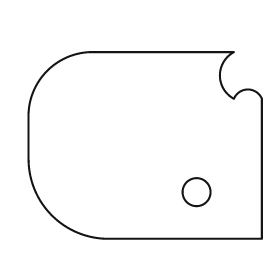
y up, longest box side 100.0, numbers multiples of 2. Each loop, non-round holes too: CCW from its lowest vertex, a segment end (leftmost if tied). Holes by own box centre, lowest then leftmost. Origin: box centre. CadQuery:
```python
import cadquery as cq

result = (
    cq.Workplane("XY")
    .moveTo(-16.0, -40.0)
    .lineTo(50.0, -40.0)
    .lineTo(50.0, 20.0)
    .threePointArc((44.0, 24.0), (38.0, 20.0))
    .threePointArc((32.0, 30.0), (38.0, 40.0))
    .lineTo(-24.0, 40.0)
    .threePointArc((-42.0, 32.0), (-50.0, 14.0))
    .lineTo(-50.0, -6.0)
    .threePointArc((-40.0, -30.0), (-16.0, -40.0))
    .close()
    .moveTo(22.0, -20.0)
    .circle(6.0)
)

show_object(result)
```